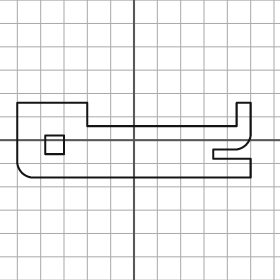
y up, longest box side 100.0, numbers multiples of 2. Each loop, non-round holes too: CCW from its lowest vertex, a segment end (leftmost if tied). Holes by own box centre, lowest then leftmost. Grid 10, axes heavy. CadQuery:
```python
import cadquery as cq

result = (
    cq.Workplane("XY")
    .moveTo(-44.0, -16.0)
    .lineTo(50.0, -16.0)
    .lineTo(50.0, -8.0)
    .lineTo(34.0, -8.0)
    .lineTo(34.0, -4.0)
    .lineTo(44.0, -4.0)
    .threePointArc((48.0, -2.0), (50.0, 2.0))
    .lineTo(50.0, 16.0)
    .lineTo(44.0, 16.0)
    .lineTo(44.0, 6.0)
    .lineTo(-20.0, 6.0)
    .lineTo(-20.0, 16.0)
    .lineTo(-50.0, 16.0)
    .lineTo(-50.0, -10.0)
    .threePointArc((-48.0, -14.0), (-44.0, -16.0))
    .close()
    .moveTo(-38.0, -6.0)
    .lineTo(-30.0, -6.0)
    .lineTo(-30.0, 2.0)
    .lineTo(-38.0, 2.0)
    .close()
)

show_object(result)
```